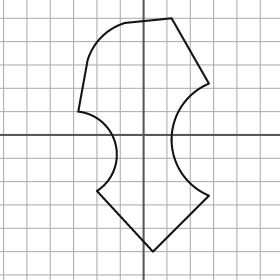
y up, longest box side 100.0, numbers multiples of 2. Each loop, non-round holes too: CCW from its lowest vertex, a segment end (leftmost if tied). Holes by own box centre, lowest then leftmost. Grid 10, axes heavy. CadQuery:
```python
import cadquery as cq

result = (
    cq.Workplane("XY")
    .moveTo(4.0, -50.0)
    .lineTo(28.0, -26.0)
    .threePointArc((12.0, -2.0), (28.0, 22.0))
    .lineTo(12.0, 50.0)
    .lineTo(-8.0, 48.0)
    .threePointArc((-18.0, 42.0), (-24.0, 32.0))
    .lineTo(-28.0, 10.0)
    .threePointArc((-12.0, -4.0), (-20.0, -24.0))
    .close()
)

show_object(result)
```